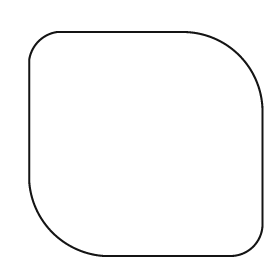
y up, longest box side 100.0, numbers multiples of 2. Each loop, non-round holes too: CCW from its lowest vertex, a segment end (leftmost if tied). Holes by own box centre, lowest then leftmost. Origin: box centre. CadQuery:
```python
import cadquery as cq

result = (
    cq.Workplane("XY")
    .moveTo(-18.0, -48.0)
    .lineTo(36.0, -48.0)
    .threePointArc((46.0, -44.0), (50.0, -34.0))
    .lineTo(50.0, 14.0)
    .threePointArc((40.0, 38.0), (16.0, 48.0))
    .lineTo(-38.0, 48.0)
    .threePointArc((-46.0, 44.0), (-50.0, 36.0))
    .lineTo(-50.0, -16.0)
    .threePointArc((-40.0, -38.0), (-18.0, -48.0))
    .close()
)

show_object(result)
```